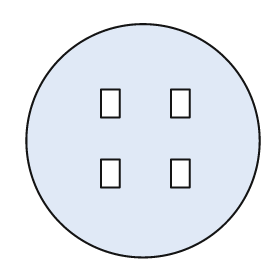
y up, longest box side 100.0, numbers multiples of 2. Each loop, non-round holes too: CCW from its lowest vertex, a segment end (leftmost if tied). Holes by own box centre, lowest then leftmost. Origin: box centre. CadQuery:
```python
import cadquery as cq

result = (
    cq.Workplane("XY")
    .moveTo(0.0, 0.0)
    .circle(50.0)
    .moveTo(-18.0, -20.0)
    .lineTo(-10.0, -20.0)
    .lineTo(-10.0, -8.0)
    .lineTo(-18.0, -8.0)
    .close()
    .moveTo(12.0, -20.0)
    .lineTo(20.0, -20.0)
    .lineTo(20.0, -8.0)
    .lineTo(12.0, -8.0)
    .close()
    .moveTo(-18.0, 10.0)
    .lineTo(-10.0, 10.0)
    .lineTo(-10.0, 22.0)
    .lineTo(-18.0, 22.0)
    .close()
    .moveTo(12.0, 10.0)
    .lineTo(20.0, 10.0)
    .lineTo(20.0, 22.0)
    .lineTo(12.0, 22.0)
    .close()
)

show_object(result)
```